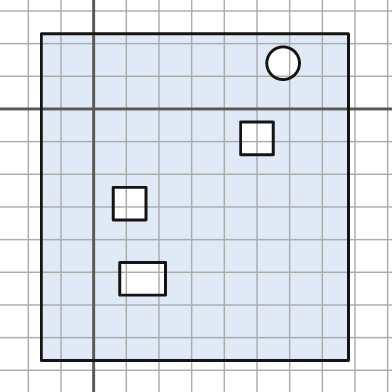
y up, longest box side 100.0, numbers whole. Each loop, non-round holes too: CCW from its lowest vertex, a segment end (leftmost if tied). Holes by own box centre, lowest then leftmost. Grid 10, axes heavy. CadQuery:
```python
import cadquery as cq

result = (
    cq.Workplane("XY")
    .moveTo(-16.0, -77.0)
    .lineTo(78.0, -77.0)
    .lineTo(78.0, 23.0)
    .lineTo(-16.0, 23.0)
    .close()
    .moveTo(8.0, -57.0)
    .lineTo(22.0, -57.0)
    .lineTo(22.0, -47.0)
    .lineTo(8.0, -47.0)
    .close()
    .moveTo(6.0, -34.0)
    .lineTo(16.0, -34.0)
    .lineTo(16.0, -24.0)
    .lineTo(6.0, -24.0)
    .close()
    .moveTo(45.0, -14.0)
    .lineTo(55.0, -14.0)
    .lineTo(55.0, -4.0)
    .lineTo(45.0, -4.0)
    .close()
    .moveTo(58.0, 14.0)
    .circle(5.0)
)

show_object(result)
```